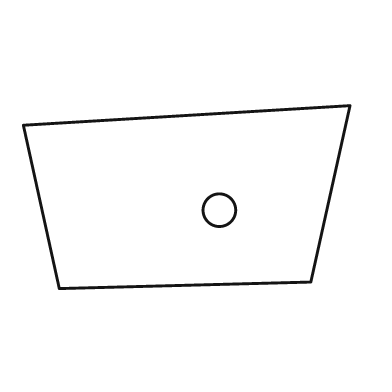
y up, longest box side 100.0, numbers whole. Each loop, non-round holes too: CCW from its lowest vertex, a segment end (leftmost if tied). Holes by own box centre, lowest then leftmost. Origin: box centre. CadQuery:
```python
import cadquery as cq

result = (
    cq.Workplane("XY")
    .moveTo(-39.0, -28.0)
    .lineTo(38.0, -26.0)
    .lineTo(50.0, 28.0)
    .lineTo(-50.0, 22.0)
    .close()
    .moveTo(10.0, -4.0)
    .circle(5.0)
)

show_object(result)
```